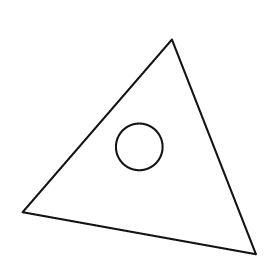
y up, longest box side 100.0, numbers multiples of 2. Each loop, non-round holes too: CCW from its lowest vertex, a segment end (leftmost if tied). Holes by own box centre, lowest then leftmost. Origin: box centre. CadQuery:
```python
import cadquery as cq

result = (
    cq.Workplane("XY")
    .moveTo(50.0, -46.0)
    .lineTo(14.0, 46.0)
    .lineTo(-50.0, -28.0)
    .close()
    .moveTo(0.0, 0.0)
    .circle(10.0)
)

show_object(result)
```